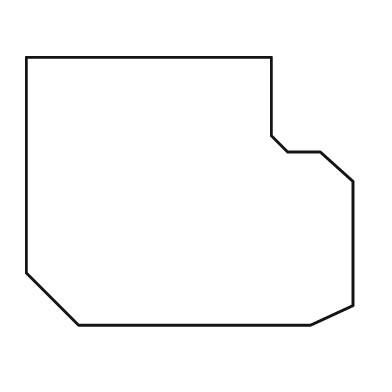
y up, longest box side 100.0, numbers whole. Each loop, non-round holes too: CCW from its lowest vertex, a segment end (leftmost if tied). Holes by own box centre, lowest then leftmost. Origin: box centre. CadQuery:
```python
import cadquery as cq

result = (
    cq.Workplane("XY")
    .moveTo(-34.0, -41.0)
    .lineTo(37.0, -41.0)
    .lineTo(50.0, -35.0)
    .lineTo(50.0, 3.0)
    .lineTo(40.0, 12.0)
    .lineTo(30.0, 12.0)
    .lineTo(25.0, 17.0)
    .lineTo(25.0, 41.0)
    .lineTo(-50.0, 41.0)
    .lineTo(-50.0, -25.0)
    .close()
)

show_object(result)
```